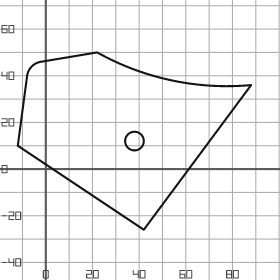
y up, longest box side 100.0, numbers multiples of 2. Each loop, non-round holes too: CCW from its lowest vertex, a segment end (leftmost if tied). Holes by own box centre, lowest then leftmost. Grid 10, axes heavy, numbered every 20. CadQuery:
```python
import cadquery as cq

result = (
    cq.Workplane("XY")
    .moveTo(42.0, -26.0)
    .lineTo(88.0, 36.0)
    .threePointArc((54.0, 38.0), (22.0, 50.0))
    .lineTo(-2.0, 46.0)
    .threePointArc((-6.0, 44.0), (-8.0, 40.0))
    .lineTo(-12.0, 10.0)
    .close()
    .moveTo(38.0, 12.0)
    .circle(4.0)
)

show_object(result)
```